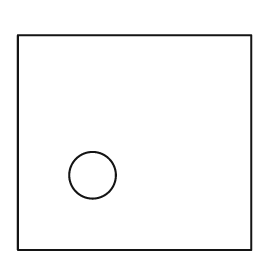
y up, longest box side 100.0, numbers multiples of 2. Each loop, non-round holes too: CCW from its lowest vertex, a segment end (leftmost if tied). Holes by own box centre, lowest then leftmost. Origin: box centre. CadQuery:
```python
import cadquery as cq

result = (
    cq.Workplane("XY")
    .moveTo(-50.0, -46.0)
    .lineTo(50.0, -46.0)
    .lineTo(50.0, 46.0)
    .lineTo(-50.0, 46.0)
    .close()
    .moveTo(-18.0, -14.0)
    .circle(10.0)
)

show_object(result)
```